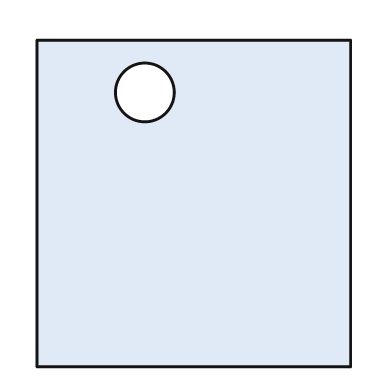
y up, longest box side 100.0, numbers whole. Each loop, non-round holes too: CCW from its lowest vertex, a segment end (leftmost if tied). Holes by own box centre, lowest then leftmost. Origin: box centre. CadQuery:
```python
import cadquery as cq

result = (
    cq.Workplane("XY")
    .moveTo(-48.0, -50.0)
    .lineTo(48.0, -50.0)
    .lineTo(48.0, 50.0)
    .lineTo(-48.0, 50.0)
    .close()
    .moveTo(-15.0, 34.0)
    .circle(9.0)
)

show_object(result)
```